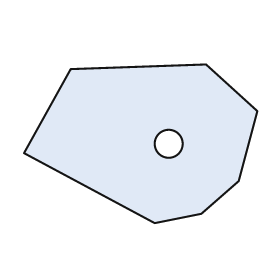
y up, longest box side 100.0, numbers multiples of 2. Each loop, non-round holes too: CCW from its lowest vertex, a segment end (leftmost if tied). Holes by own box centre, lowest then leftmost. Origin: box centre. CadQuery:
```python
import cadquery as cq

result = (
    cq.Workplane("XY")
    .moveTo(6.0, -34.0)
    .lineTo(26.0, -30.0)
    .lineTo(42.0, -16.0)
    .lineTo(50.0, 14.0)
    .lineTo(28.0, 34.0)
    .lineTo(-30.0, 32.0)
    .lineTo(-50.0, -4.0)
    .close()
    .moveTo(12.0, 0.0)
    .circle(6.0)
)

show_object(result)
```